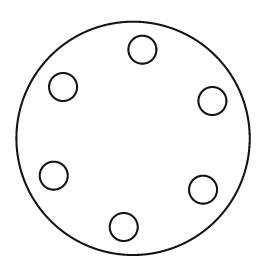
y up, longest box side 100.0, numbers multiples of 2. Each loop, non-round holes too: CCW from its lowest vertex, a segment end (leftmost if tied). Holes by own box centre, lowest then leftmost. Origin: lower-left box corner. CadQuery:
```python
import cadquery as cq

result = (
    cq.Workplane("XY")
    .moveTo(50.0, 50.0)
    .circle(50.0)
    .moveTo(46.0, 12.0)
    .circle(6.0)
    .moveTo(80.0, 28.0)
    .circle(6.0)
    .moveTo(16.0, 34.0)
    .circle(6.0)
    .moveTo(84.0, 66.0)
    .circle(6.0)
    .moveTo(20.0, 72.0)
    .circle(6.0)
    .moveTo(54.0, 88.0)
    .circle(6.0)
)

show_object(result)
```